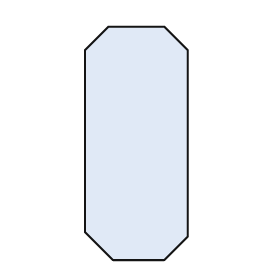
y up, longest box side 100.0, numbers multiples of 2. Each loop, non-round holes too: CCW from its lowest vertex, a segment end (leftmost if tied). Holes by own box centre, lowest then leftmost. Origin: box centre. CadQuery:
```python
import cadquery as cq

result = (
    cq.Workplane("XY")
    .moveTo(-10.0, -50.0)
    .lineTo(12.0, -50.0)
    .lineTo(22.0, -40.0)
    .lineTo(22.0, 40.0)
    .lineTo(12.0, 50.0)
    .lineTo(-12.0, 50.0)
    .lineTo(-22.0, 40.0)
    .lineTo(-22.0, -38.0)
    .close()
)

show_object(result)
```